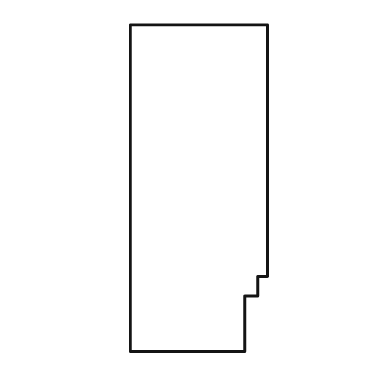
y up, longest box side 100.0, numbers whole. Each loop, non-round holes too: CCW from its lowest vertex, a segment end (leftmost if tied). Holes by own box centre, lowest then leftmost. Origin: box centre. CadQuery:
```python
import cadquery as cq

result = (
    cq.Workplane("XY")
    .moveTo(-21.0, -50.0)
    .lineTo(14.0, -50.0)
    .lineTo(14.0, -33.0)
    .lineTo(18.0, -33.0)
    .lineTo(18.0, -27.0)
    .lineTo(21.0, -27.0)
    .lineTo(21.0, 50.0)
    .lineTo(-21.0, 50.0)
    .close()
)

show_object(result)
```